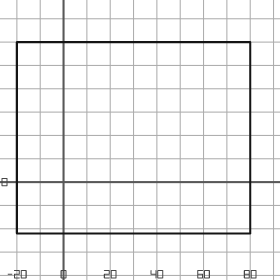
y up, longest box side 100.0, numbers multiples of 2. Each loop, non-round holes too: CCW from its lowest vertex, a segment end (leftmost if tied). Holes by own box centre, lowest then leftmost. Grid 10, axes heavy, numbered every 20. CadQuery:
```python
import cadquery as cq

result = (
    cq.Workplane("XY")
    .moveTo(-20.0, -22.0)
    .lineTo(80.0, -22.0)
    .lineTo(80.0, 60.0)
    .lineTo(-20.0, 60.0)
    .close()
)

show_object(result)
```